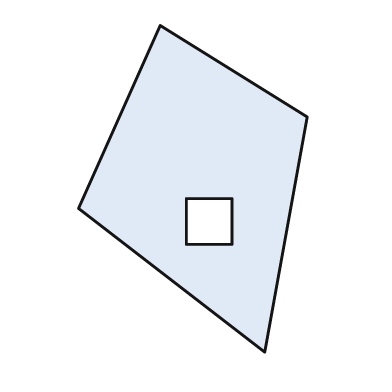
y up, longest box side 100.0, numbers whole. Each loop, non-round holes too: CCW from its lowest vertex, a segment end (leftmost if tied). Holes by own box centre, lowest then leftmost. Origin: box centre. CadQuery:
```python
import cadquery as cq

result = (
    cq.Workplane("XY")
    .moveTo(22.0, -50.0)
    .lineTo(35.0, 22.0)
    .lineTo(-10.0, 50.0)
    .lineTo(-35.0, -6.0)
    .close()
    .moveTo(-2.0, -17.0)
    .lineTo(12.0, -17.0)
    .lineTo(12.0, -3.0)
    .lineTo(-2.0, -3.0)
    .close()
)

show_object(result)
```